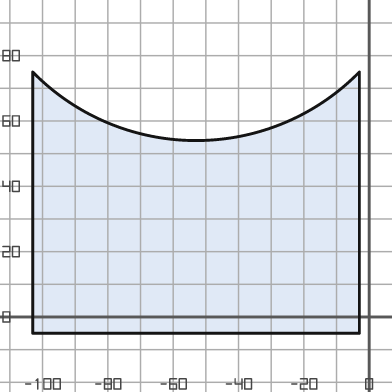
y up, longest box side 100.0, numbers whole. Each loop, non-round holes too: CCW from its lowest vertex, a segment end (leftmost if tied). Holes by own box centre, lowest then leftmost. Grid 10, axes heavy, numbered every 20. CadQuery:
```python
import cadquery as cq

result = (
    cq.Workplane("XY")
    .moveTo(-103.0, -5.0)
    .lineTo(-3.0, -5.0)
    .lineTo(-3.0, 75.0)
    .threePointArc((-53.0, 54.0), (-103.0, 75.0))
    .close()
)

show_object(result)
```